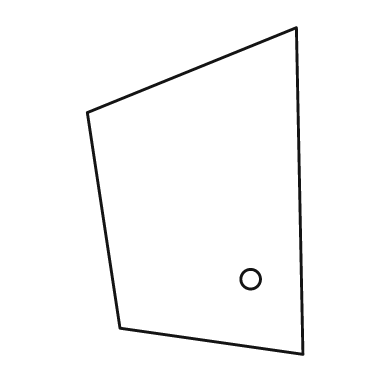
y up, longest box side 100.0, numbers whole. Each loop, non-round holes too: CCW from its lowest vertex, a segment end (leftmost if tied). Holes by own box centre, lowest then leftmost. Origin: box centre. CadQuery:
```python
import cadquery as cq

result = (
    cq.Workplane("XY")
    .moveTo(33.0, -50.0)
    .lineTo(31.0, 50.0)
    .lineTo(-33.0, 24.0)
    .lineTo(-23.0, -42.0)
    .close()
    .moveTo(17.0, -27.0)
    .circle(3.0)
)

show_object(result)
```